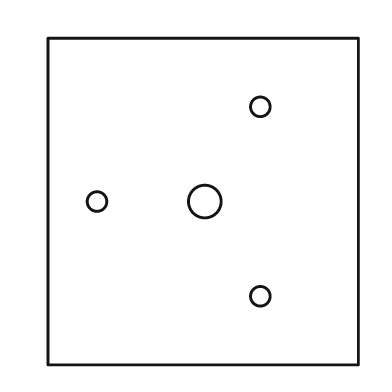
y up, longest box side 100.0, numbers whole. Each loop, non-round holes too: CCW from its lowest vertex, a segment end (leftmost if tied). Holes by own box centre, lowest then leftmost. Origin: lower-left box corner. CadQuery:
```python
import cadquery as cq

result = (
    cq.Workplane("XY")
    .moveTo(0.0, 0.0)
    .lineTo(95.0, 0.0)
    .lineTo(95.0, 100.0)
    .lineTo(0.0, 100.0)
    .close()
    .moveTo(65.0, 21.0)
    .circle(3.0)
    .moveTo(15.0, 50.0)
    .circle(3.0)
    .moveTo(48.0, 50.0)
    .circle(5.0)
    .moveTo(65.0, 79.0)
    .circle(3.0)
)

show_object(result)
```